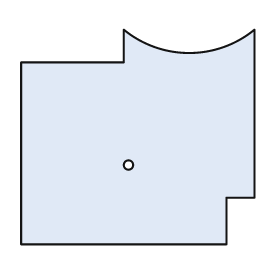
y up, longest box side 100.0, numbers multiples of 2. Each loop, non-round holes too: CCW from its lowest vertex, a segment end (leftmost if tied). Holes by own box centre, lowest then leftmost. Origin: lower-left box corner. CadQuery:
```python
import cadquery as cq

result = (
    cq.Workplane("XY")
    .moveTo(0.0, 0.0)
    .lineTo(88.0, 0.0)
    .lineTo(88.0, 20.0)
    .lineTo(100.0, 20.0)
    .lineTo(100.0, 92.0)
    .threePointArc((72.0, 82.0), (44.0, 92.0))
    .lineTo(44.0, 78.0)
    .lineTo(0.0, 78.0)
    .close()
    .moveTo(46.0, 34.0)
    .circle(2.0)
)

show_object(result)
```